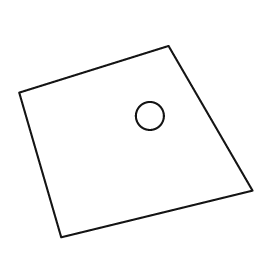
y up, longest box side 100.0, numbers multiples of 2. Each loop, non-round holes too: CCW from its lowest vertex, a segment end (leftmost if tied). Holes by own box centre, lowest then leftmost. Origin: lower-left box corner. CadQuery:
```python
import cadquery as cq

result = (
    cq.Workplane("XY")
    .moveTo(18.0, 0.0)
    .lineTo(100.0, 20.0)
    .lineTo(64.0, 82.0)
    .lineTo(0.0, 62.0)
    .close()
    .moveTo(56.0, 52.0)
    .circle(6.0)
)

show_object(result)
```